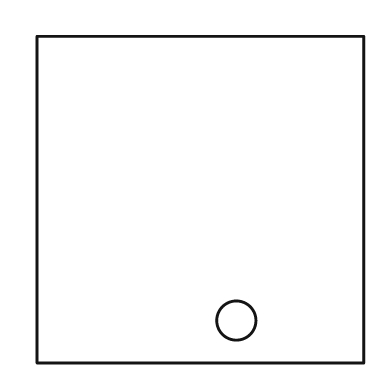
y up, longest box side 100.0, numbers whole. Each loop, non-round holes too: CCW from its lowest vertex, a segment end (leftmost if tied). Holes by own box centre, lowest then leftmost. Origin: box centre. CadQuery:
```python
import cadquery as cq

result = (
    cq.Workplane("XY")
    .moveTo(-50.0, -50.0)
    .lineTo(50.0, -50.0)
    .lineTo(50.0, 50.0)
    .lineTo(-50.0, 50.0)
    .close()
    .moveTo(11.0, -37.0)
    .circle(6.0)
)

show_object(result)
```